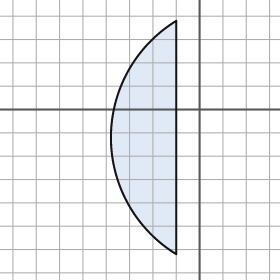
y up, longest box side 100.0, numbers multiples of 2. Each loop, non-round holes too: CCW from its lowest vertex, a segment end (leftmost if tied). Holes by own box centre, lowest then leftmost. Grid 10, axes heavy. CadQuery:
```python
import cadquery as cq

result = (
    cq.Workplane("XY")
    .moveTo(-10.0, -62.0)
    .lineTo(-10.0, 38.0)
    .threePointArc((-38.0, -12.0), (-10.0, -62.0))
    .close()
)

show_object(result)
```